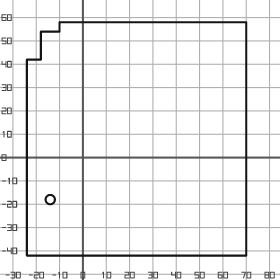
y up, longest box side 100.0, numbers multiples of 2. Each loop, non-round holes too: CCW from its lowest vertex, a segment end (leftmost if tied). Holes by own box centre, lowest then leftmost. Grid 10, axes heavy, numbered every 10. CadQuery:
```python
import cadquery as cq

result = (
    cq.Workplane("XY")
    .moveTo(-24.0, -42.0)
    .lineTo(70.0, -42.0)
    .lineTo(70.0, 58.0)
    .lineTo(-10.0, 58.0)
    .lineTo(-10.0, 54.0)
    .lineTo(-18.0, 54.0)
    .lineTo(-18.0, 42.0)
    .lineTo(-24.0, 42.0)
    .close()
    .moveTo(-14.0, -18.0)
    .circle(2.0)
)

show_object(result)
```